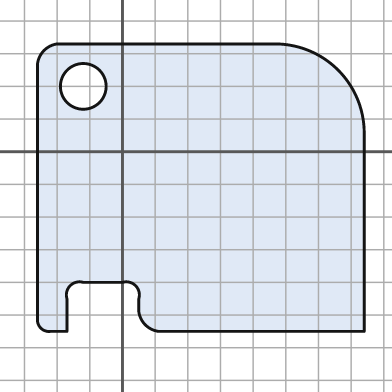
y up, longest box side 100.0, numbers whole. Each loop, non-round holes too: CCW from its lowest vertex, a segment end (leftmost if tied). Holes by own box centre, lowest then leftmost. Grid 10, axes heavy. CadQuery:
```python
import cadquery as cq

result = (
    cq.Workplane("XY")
    .moveTo(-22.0, -55.0)
    .lineTo(-17.0, -55.0)
    .lineTo(-17.0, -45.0)
    .threePointArc((-16.0, -41.0), (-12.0, -40.0))
    .lineTo(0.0, -40.0)
    .threePointArc((4.0, -41.0), (5.0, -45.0))
    .lineTo(5.0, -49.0)
    .threePointArc((7.0, -53.0), (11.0, -55.0))
    .lineTo(74.0, -55.0)
    .lineTo(74.0, 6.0)
    .threePointArc((66.0, 25.0), (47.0, 33.0))
    .lineTo(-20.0, 33.0)
    .threePointArc((-24.0, 31.0), (-26.0, 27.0))
    .lineTo(-26.0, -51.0)
    .threePointArc((-25.0, -54.0), (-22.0, -55.0))
    .close()
    .moveTo(-12.0, 20.0)
    .circle(7.0)
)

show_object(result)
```